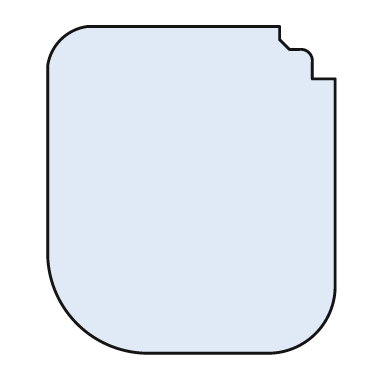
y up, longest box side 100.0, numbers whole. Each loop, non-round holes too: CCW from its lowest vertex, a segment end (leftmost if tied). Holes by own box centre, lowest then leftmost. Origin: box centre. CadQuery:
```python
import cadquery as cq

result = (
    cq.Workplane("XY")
    .moveTo(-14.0, -50.0)
    .lineTo(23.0, -50.0)
    .threePointArc((38.0, -44.0), (44.0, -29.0))
    .lineTo(44.0, 34.0)
    .lineTo(37.0, 34.0)
    .lineTo(37.0, 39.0)
    .threePointArc((36.0, 42.0), (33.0, 43.0))
    .lineTo(30.0, 43.0)
    .lineTo(27.0, 46.0)
    .lineTo(27.0, 50.0)
    .lineTo(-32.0, 50.0)
    .threePointArc((-40.0, 46.0), (-44.0, 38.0))
    .lineTo(-44.0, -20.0)
    .threePointArc((-35.0, -41.0), (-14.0, -50.0))
    .close()
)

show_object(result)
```